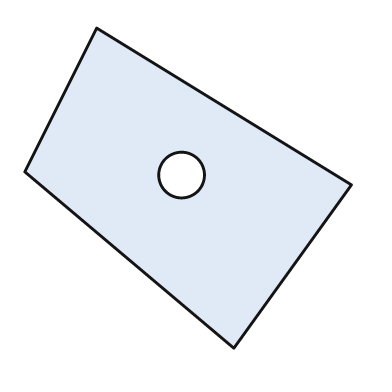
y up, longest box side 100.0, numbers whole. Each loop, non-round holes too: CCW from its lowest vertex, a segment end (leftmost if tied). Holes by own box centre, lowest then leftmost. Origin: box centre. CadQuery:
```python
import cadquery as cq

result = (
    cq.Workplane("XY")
    .moveTo(14.0, -49.0)
    .lineTo(50.0, 1.0)
    .lineTo(-28.0, 49.0)
    .lineTo(-50.0, 5.0)
    .close()
    .moveTo(-2.0, 4.0)
    .circle(7.0)
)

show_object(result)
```